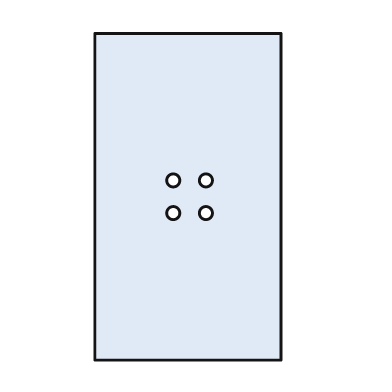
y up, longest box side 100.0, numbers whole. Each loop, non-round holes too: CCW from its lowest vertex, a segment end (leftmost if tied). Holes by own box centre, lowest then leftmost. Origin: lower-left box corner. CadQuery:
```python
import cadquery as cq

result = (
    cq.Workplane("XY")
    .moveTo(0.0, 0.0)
    .lineTo(57.0, 0.0)
    .lineTo(57.0, 100.0)
    .lineTo(0.0, 100.0)
    .close()
    .moveTo(24.0, 45.0)
    .circle(2.0)
    .moveTo(34.0, 45.0)
    .circle(2.0)
    .moveTo(24.0, 55.0)
    .circle(2.0)
    .moveTo(34.0, 55.0)
    .circle(2.0)
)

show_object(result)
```